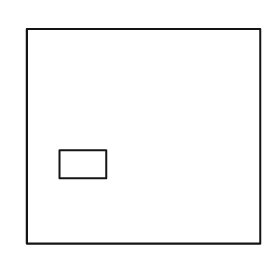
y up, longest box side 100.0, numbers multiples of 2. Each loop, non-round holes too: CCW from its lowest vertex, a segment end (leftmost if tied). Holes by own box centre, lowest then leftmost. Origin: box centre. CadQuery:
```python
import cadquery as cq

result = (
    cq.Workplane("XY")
    .moveTo(-50.0, -46.0)
    .lineTo(50.0, -46.0)
    .lineTo(50.0, 46.0)
    .lineTo(-50.0, 46.0)
    .close()
    .moveTo(-36.0, -18.0)
    .lineTo(-16.0, -18.0)
    .lineTo(-16.0, -6.0)
    .lineTo(-36.0, -6.0)
    .close()
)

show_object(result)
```